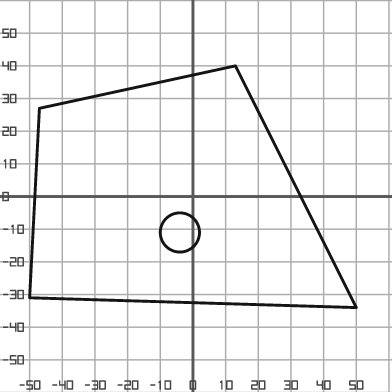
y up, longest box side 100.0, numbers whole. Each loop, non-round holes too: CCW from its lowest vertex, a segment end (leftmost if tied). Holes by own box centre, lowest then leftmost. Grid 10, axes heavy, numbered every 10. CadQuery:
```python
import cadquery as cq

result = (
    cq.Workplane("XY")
    .moveTo(50.0, -34.0)
    .lineTo(13.0, 40.0)
    .lineTo(-47.0, 27.0)
    .lineTo(-50.0, -31.0)
    .close()
    .moveTo(-4.0, -11.0)
    .circle(6.0)
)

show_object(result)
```